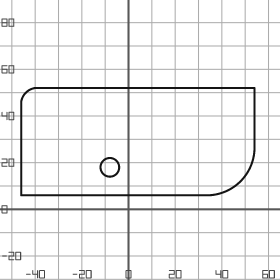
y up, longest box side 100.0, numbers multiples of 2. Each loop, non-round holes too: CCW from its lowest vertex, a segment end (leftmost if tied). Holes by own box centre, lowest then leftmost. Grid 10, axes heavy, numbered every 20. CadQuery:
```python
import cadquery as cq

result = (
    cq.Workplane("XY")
    .moveTo(-46.0, 6.0)
    .lineTo(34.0, 6.0)
    .threePointArc((48.0, 12.0), (54.0, 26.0))
    .lineTo(54.0, 52.0)
    .lineTo(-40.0, 52.0)
    .threePointArc((-44.0, 50.0), (-46.0, 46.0))
    .close()
    .moveTo(-8.0, 18.0)
    .circle(4.0)
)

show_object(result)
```